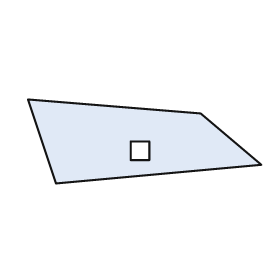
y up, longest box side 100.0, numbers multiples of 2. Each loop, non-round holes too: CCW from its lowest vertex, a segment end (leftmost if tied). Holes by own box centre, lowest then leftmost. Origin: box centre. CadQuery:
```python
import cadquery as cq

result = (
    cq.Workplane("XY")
    .moveTo(-38.0, -18.0)
    .lineTo(50.0, -10.0)
    .lineTo(24.0, 12.0)
    .lineTo(-50.0, 18.0)
    .close()
    .moveTo(-6.0, -8.0)
    .lineTo(2.0, -8.0)
    .lineTo(2.0, 0.0)
    .lineTo(-6.0, 0.0)
    .close()
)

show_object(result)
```